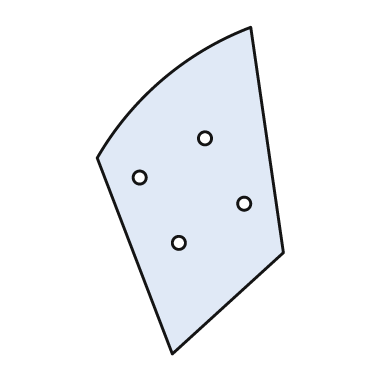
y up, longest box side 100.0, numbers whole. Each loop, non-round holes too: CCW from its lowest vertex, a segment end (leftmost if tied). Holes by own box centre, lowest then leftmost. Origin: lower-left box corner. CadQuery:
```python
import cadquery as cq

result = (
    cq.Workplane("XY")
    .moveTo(23.0, 0.0)
    .lineTo(57.0, 31.0)
    .lineTo(47.0, 100.0)
    .threePointArc((20.0, 84.0), (0.0, 60.0))
    .close()
    .moveTo(25.0, 34.0)
    .circle(2.0)
    .moveTo(45.0, 46.0)
    .circle(2.0)
    .moveTo(13.0, 54.0)
    .circle(2.0)
    .moveTo(33.0, 66.0)
    .circle(2.0)
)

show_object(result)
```